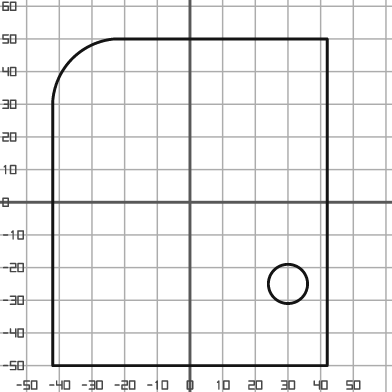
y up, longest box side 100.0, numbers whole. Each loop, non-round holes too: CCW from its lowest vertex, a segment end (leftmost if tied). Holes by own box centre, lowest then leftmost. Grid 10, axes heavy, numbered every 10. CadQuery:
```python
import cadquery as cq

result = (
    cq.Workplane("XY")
    .moveTo(-42.0, -50.0)
    .lineTo(42.0, -50.0)
    .lineTo(42.0, 50.0)
    .lineTo(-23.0, 50.0)
    .threePointArc((-36.0, 44.0), (-42.0, 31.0))
    .close()
    .moveTo(30.0, -25.0)
    .circle(6.0)
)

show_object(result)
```